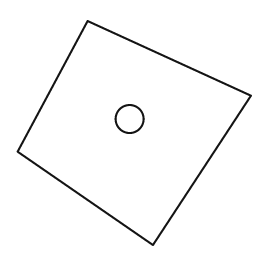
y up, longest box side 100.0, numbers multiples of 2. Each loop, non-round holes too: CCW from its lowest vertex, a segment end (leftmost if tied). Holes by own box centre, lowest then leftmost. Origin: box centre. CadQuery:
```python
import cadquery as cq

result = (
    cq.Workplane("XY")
    .moveTo(8.0, -48.0)
    .lineTo(50.0, 16.0)
    .lineTo(-20.0, 48.0)
    .lineTo(-50.0, -8.0)
    .close()
    .moveTo(-2.0, 6.0)
    .circle(6.0)
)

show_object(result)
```